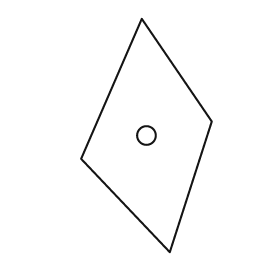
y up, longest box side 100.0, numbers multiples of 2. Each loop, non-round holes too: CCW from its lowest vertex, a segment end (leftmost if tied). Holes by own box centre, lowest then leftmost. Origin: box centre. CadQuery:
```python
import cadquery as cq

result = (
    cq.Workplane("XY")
    .moveTo(10.0, -50.0)
    .lineTo(28.0, 6.0)
    .lineTo(-2.0, 50.0)
    .lineTo(-28.0, -10.0)
    .close()
    .moveTo(0.0, 0.0)
    .circle(4.0)
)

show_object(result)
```